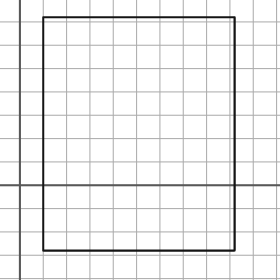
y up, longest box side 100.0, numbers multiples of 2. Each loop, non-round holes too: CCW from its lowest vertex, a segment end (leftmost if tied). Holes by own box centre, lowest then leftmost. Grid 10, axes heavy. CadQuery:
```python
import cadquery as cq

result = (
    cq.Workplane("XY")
    .moveTo(10.0, -28.0)
    .lineTo(92.0, -28.0)
    .lineTo(92.0, 72.0)
    .lineTo(10.0, 72.0)
    .close()
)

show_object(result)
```